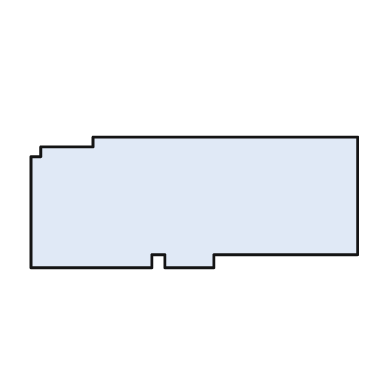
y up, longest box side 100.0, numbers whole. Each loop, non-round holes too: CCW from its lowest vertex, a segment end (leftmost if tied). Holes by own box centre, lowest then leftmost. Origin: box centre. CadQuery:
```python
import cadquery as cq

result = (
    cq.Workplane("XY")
    .moveTo(-50.0, -20.0)
    .lineTo(-13.0, -20.0)
    .lineTo(-13.0, -16.0)
    .lineTo(-9.0, -16.0)
    .lineTo(-9.0, -20.0)
    .lineTo(6.0, -20.0)
    .lineTo(6.0, -16.0)
    .lineTo(50.0, -16.0)
    .lineTo(50.0, 20.0)
    .lineTo(-31.0, 20.0)
    .lineTo(-31.0, 17.0)
    .lineTo(-47.0, 17.0)
    .lineTo(-47.0, 14.0)
    .lineTo(-50.0, 14.0)
    .close()
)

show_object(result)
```